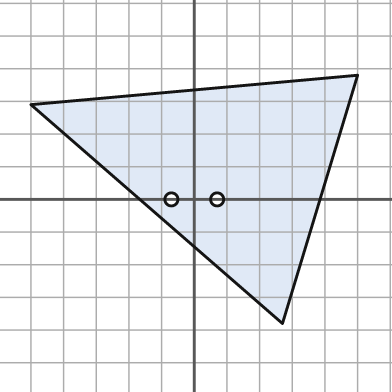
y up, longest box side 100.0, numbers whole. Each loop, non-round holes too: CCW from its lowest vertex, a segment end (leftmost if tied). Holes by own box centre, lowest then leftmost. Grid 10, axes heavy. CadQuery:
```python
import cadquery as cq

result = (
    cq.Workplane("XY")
    .moveTo(27.0, -38.0)
    .lineTo(50.0, 38.0)
    .lineTo(-50.0, 29.0)
    .close()
    .moveTo(-7.0, 0.0)
    .circle(2.0)
    .moveTo(7.0, 0.0)
    .circle(2.0)
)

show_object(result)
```